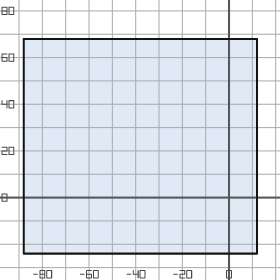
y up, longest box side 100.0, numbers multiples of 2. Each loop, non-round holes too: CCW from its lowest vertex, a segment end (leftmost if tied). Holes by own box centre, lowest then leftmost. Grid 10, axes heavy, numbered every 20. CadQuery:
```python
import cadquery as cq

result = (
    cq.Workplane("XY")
    .moveTo(-88.0, -24.0)
    .lineTo(12.0, -24.0)
    .lineTo(12.0, 68.0)
    .lineTo(-88.0, 68.0)
    .close()
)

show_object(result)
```